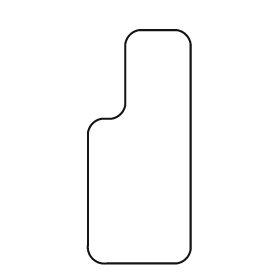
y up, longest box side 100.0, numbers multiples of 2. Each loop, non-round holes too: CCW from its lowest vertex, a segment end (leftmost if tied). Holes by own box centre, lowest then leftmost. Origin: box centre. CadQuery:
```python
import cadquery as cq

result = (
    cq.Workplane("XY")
    .moveTo(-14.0, -50.0)
    .lineTo(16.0, -50.0)
    .threePointArc((20.0, -48.0), (22.0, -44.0))
    .lineTo(22.0, 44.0)
    .threePointArc((20.0, 48.0), (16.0, 50.0))
    .lineTo(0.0, 50.0)
    .threePointArc((-4.0, 48.0), (-6.0, 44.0))
    .lineTo(-6.0, 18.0)
    .threePointArc((-8.0, 14.0), (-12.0, 12.0))
    .lineTo(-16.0, 12.0)
    .threePointArc((-20.0, 10.0), (-22.0, 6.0))
    .lineTo(-22.0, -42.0)
    .threePointArc((-20.0, -48.0), (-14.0, -50.0))
    .close()
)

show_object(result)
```